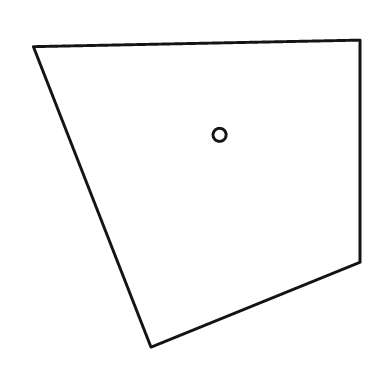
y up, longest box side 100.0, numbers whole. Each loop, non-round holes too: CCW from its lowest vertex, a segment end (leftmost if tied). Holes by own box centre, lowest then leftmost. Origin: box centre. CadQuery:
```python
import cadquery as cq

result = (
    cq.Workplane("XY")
    .moveTo(-14.0, -47.0)
    .lineTo(50.0, -21.0)
    .lineTo(50.0, 47.0)
    .lineTo(-50.0, 45.0)
    .close()
    .moveTo(7.0, 18.0)
    .circle(2.0)
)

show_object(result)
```